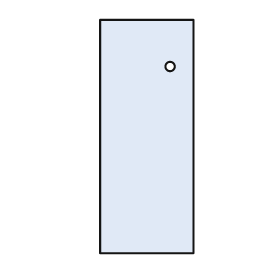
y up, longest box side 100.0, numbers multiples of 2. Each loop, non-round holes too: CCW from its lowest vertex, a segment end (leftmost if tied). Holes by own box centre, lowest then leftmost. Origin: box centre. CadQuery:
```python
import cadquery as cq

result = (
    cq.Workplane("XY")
    .moveTo(-20.0, -50.0)
    .lineTo(20.0, -50.0)
    .lineTo(20.0, 50.0)
    .lineTo(-20.0, 50.0)
    .close()
    .moveTo(10.0, 30.0)
    .circle(2.0)
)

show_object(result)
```